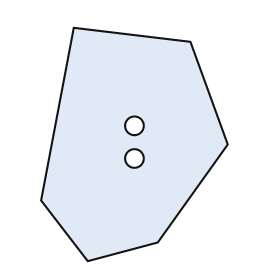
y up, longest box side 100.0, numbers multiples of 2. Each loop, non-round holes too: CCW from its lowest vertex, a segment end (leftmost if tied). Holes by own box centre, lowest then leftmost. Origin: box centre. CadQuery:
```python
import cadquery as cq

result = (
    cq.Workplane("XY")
    .moveTo(-20.0, -50.0)
    .lineTo(10.0, -42.0)
    .lineTo(40.0, 0.0)
    .lineTo(24.0, 44.0)
    .lineTo(-26.0, 50.0)
    .lineTo(-40.0, -24.0)
    .close()
    .moveTo(0.0, -6.0)
    .circle(4.0)
    .moveTo(0.0, 8.0)
    .circle(4.0)
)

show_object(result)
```